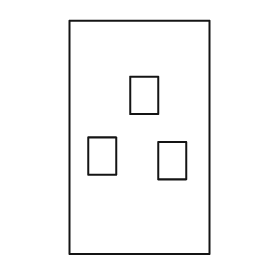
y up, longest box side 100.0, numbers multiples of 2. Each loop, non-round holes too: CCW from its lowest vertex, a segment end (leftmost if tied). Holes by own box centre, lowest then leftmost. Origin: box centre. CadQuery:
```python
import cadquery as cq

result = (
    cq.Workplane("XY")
    .moveTo(-30.0, -50.0)
    .lineTo(30.0, -50.0)
    .lineTo(30.0, 50.0)
    .lineTo(-30.0, 50.0)
    .close()
    .moveTo(8.0, -18.0)
    .lineTo(20.0, -18.0)
    .lineTo(20.0, -2.0)
    .lineTo(8.0, -2.0)
    .close()
    .moveTo(-22.0, -16.0)
    .lineTo(-10.0, -16.0)
    .lineTo(-10.0, 0.0)
    .lineTo(-22.0, 0.0)
    .close()
    .moveTo(-4.0, 10.0)
    .lineTo(8.0, 10.0)
    .lineTo(8.0, 26.0)
    .lineTo(-4.0, 26.0)
    .close()
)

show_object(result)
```